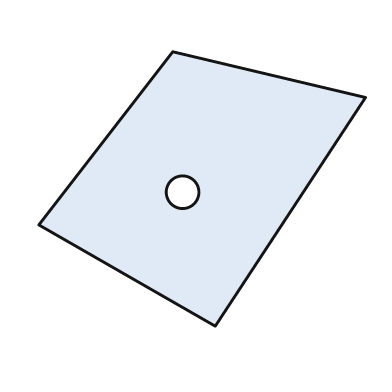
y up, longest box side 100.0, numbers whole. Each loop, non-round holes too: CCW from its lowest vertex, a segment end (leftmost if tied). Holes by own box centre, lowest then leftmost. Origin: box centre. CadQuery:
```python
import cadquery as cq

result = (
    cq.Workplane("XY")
    .moveTo(4.0, -42.0)
    .lineTo(50.0, 28.0)
    .lineTo(-9.0, 42.0)
    .lineTo(-50.0, -11.0)
    .close()
    .moveTo(-6.0, -1.0)
    .circle(5.0)
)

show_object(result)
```